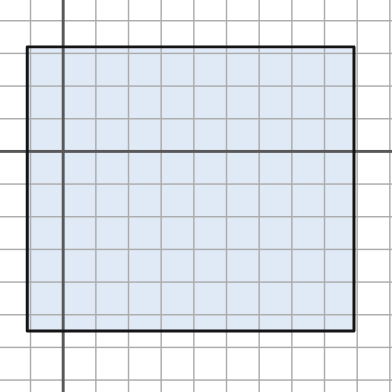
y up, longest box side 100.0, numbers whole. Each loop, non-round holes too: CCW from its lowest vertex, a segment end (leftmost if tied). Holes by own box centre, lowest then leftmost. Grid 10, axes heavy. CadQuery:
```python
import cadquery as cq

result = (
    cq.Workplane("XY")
    .moveTo(-11.0, -55.0)
    .lineTo(89.0, -55.0)
    .lineTo(89.0, 32.0)
    .lineTo(-11.0, 32.0)
    .close()
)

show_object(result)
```